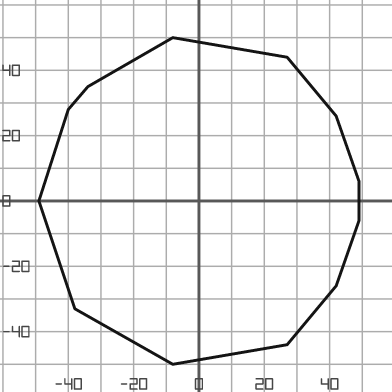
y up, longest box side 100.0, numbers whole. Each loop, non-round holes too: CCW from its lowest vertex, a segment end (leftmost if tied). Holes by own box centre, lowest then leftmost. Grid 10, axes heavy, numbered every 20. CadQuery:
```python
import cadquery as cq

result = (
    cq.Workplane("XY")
    .moveTo(-8.0, -50.0)
    .lineTo(27.0, -44.0)
    .lineTo(42.0, -26.0)
    .lineTo(49.0, -6.0)
    .lineTo(49.0, 6.0)
    .lineTo(42.0, 26.0)
    .lineTo(27.0, 44.0)
    .lineTo(-8.0, 50.0)
    .lineTo(-34.0, 35.0)
    .lineTo(-40.0, 28.0)
    .lineTo(-49.0, 0.0)
    .lineTo(-38.0, -33.0)
    .close()
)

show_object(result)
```